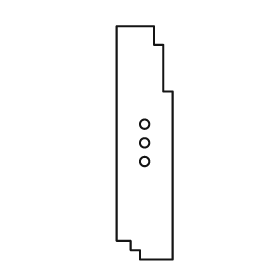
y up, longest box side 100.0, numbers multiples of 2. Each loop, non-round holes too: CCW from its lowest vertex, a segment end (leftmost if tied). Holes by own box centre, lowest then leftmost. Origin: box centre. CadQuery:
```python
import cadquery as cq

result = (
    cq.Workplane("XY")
    .moveTo(-2.0, -50.0)
    .lineTo(12.0, -50.0)
    .lineTo(12.0, 22.0)
    .lineTo(8.0, 22.0)
    .lineTo(8.0, 42.0)
    .lineTo(4.0, 42.0)
    .lineTo(4.0, 50.0)
    .lineTo(-12.0, 50.0)
    .lineTo(-12.0, -42.0)
    .lineTo(-6.0, -42.0)
    .lineTo(-6.0, -46.0)
    .lineTo(-2.0, -46.0)
    .close()
    .moveTo(0.0, -8.0)
    .circle(2.0)
    .moveTo(0.0, 0.0)
    .circle(2.0)
    .moveTo(0.0, 8.0)
    .circle(2.0)
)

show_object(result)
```